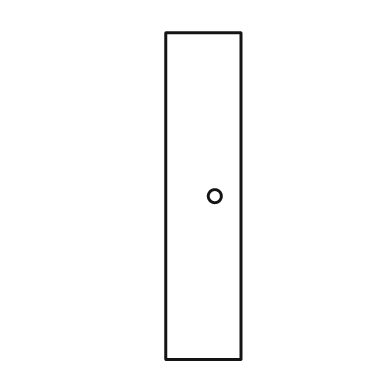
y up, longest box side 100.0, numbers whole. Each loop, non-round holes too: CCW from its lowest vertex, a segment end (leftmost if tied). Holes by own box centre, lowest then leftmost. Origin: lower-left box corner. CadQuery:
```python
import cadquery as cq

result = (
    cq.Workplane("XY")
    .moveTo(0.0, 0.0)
    .lineTo(23.0, 0.0)
    .lineTo(23.0, 100.0)
    .lineTo(0.0, 100.0)
    .close()
    .moveTo(15.0, 50.0)
    .circle(2.0)
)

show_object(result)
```